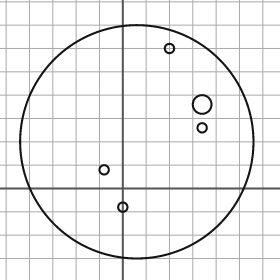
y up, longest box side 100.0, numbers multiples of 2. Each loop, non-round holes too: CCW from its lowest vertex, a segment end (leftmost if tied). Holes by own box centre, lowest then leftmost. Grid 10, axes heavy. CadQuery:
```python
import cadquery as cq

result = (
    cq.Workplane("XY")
    .moveTo(6.0, 20.0)
    .circle(50.0)
    .moveTo(0.0, -8.0)
    .circle(2.0)
    .moveTo(-8.0, 8.0)
    .circle(2.0)
    .moveTo(34.0, 26.0)
    .circle(2.0)
    .moveTo(34.0, 36.0)
    .circle(4.0)
    .moveTo(20.0, 60.0)
    .circle(2.0)
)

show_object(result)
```